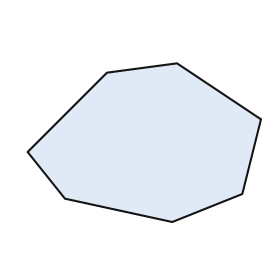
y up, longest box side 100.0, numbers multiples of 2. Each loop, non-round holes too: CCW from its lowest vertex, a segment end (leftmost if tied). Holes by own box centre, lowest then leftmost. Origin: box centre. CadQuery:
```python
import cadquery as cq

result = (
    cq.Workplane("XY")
    .moveTo(12.0, -34.0)
    .lineTo(42.0, -22.0)
    .lineTo(50.0, 10.0)
    .lineTo(14.0, 34.0)
    .lineTo(-16.0, 30.0)
    .lineTo(-50.0, -4.0)
    .lineTo(-34.0, -24.0)
    .close()
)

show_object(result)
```